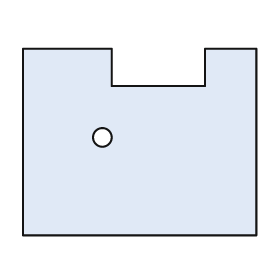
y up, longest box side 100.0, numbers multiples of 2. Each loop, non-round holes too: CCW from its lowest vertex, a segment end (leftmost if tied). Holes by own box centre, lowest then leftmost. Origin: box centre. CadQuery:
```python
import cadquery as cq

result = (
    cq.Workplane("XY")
    .moveTo(-50.0, -40.0)
    .lineTo(50.0, -40.0)
    .lineTo(50.0, 40.0)
    .lineTo(28.0, 40.0)
    .lineTo(28.0, 24.0)
    .lineTo(-12.0, 24.0)
    .lineTo(-12.0, 40.0)
    .lineTo(-50.0, 40.0)
    .close()
    .moveTo(-16.0, 2.0)
    .circle(4.0)
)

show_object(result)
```